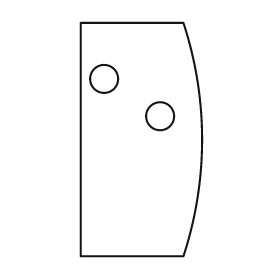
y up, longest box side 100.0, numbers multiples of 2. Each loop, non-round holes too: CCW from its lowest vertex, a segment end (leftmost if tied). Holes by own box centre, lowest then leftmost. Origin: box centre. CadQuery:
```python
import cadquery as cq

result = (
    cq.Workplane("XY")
    .moveTo(-26.0, -50.0)
    .lineTo(18.0, -50.0)
    .threePointArc((26.0, 0.0), (18.0, 50.0))
    .lineTo(-26.0, 50.0)
    .close()
    .moveTo(8.0, 10.0)
    .circle(6.0)
    .moveTo(-16.0, 26.0)
    .circle(6.0)
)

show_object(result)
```